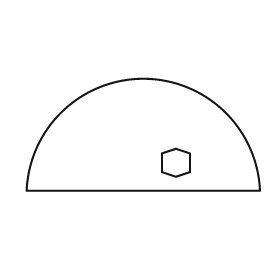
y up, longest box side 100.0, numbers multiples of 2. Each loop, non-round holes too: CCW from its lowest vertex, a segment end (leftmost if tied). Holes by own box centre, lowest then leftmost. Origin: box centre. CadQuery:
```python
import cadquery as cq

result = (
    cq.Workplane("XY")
    .moveTo(-50.0, -24.0)
    .lineTo(50.0, -24.0)
    .threePointArc((0.0, 24.0), (-50.0, -24.0))
    .close()
    .moveTo(14.0, -18.0)
    .lineTo(20.0, -16.0)
    .lineTo(20.0, -8.0)
    .lineTo(14.0, -6.0)
    .lineTo(8.0, -8.0)
    .lineTo(8.0, -16.0)
    .close()
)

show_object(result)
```